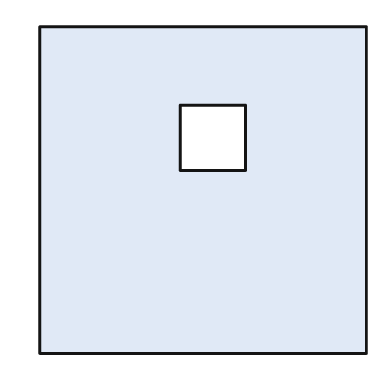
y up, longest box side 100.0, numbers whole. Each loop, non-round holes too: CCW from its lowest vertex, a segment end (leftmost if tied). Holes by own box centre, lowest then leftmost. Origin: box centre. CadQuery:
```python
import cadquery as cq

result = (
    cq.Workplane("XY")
    .moveTo(-50.0, -50.0)
    .lineTo(50.0, -50.0)
    .lineTo(50.0, 50.0)
    .lineTo(-50.0, 50.0)
    .close()
    .moveTo(-7.0, 6.0)
    .lineTo(13.0, 6.0)
    .lineTo(13.0, 26.0)
    .lineTo(-7.0, 26.0)
    .close()
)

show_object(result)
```